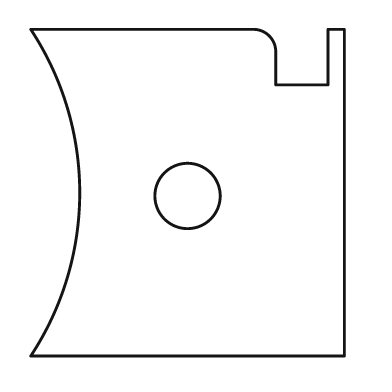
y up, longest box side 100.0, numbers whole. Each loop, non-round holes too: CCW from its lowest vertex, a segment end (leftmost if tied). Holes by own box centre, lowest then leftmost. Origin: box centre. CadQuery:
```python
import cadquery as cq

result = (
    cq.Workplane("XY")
    .moveTo(-48.0, -50.0)
    .lineTo(48.0, -50.0)
    .lineTo(48.0, 50.0)
    .lineTo(43.0, 50.0)
    .lineTo(43.0, 33.0)
    .lineTo(27.0, 33.0)
    .lineTo(27.0, 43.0)
    .threePointArc((25.0, 48.0), (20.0, 50.0))
    .lineTo(-48.0, 50.0)
    .threePointArc((-33.0, 0.0), (-48.0, -50.0))
    .close()
    .moveTo(0.0, -1.0)
    .circle(10.0)
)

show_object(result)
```